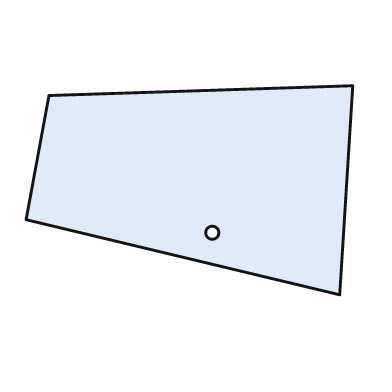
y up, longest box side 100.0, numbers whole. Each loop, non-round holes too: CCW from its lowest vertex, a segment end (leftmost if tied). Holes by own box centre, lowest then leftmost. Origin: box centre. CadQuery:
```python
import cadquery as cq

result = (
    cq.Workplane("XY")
    .moveTo(46.0, -32.0)
    .lineTo(50.0, 32.0)
    .lineTo(-43.0, 29.0)
    .lineTo(-50.0, -9.0)
    .close()
    .moveTo(7.0, -13.0)
    .circle(2.0)
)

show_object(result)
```